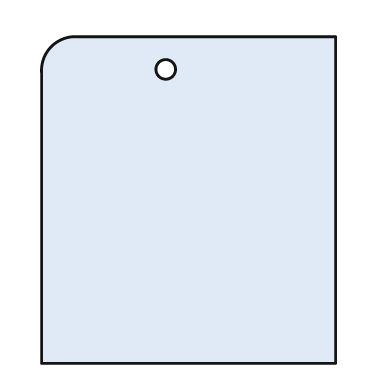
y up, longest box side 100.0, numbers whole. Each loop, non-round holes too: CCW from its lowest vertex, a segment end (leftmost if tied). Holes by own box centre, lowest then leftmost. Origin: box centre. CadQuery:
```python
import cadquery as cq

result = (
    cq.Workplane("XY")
    .moveTo(-45.0, -50.0)
    .lineTo(45.0, -50.0)
    .lineTo(45.0, 50.0)
    .lineTo(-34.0, 50.0)
    .threePointArc((-42.0, 47.0), (-45.0, 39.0))
    .close()
    .moveTo(-7.0, 40.0)
    .circle(3.0)
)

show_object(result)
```